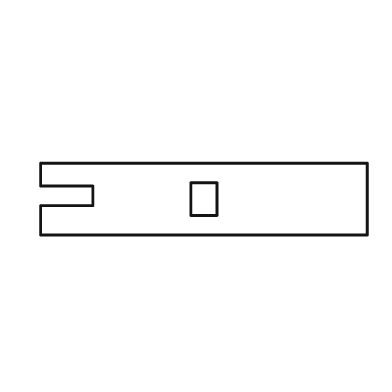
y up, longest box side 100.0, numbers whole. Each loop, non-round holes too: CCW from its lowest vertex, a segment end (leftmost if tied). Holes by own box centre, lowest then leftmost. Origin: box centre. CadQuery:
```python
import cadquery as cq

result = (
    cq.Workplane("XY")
    .moveTo(-50.0, -11.0)
    .lineTo(50.0, -11.0)
    .lineTo(50.0, 11.0)
    .lineTo(-50.0, 11.0)
    .lineTo(-50.0, 4.0)
    .lineTo(-34.0, 4.0)
    .lineTo(-34.0, -2.0)
    .lineTo(-50.0, -2.0)
    .close()
    .moveTo(-4.0, -5.0)
    .lineTo(4.0, -5.0)
    .lineTo(4.0, 5.0)
    .lineTo(-4.0, 5.0)
    .close()
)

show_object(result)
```